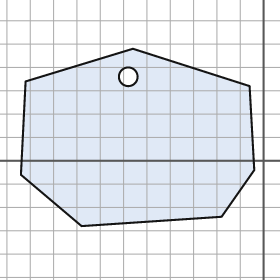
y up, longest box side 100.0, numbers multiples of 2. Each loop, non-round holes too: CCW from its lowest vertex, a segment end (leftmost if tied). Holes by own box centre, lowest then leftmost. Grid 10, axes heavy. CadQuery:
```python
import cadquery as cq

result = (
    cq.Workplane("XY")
    .moveTo(-78.0, -28.0)
    .lineTo(-18.0, -24.0)
    .lineTo(-4.0, -4.0)
    .lineTo(-6.0, 32.0)
    .lineTo(-56.0, 48.0)
    .lineTo(-102.0, 34.0)
    .lineTo(-104.0, -6.0)
    .close()
    .moveTo(-58.0, 36.0)
    .circle(4.0)
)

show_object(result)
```